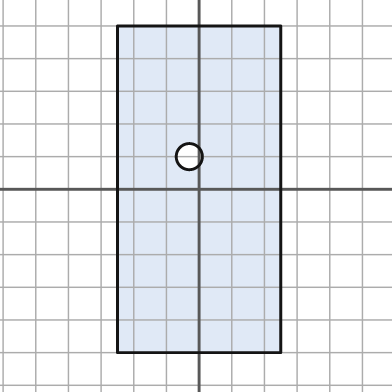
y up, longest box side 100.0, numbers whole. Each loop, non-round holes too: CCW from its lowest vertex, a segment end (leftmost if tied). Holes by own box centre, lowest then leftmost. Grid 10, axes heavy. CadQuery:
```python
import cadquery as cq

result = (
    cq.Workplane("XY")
    .moveTo(-25.0, -50.0)
    .lineTo(25.0, -50.0)
    .lineTo(25.0, 50.0)
    .lineTo(-25.0, 50.0)
    .close()
    .moveTo(-3.0, 10.0)
    .circle(4.0)
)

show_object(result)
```